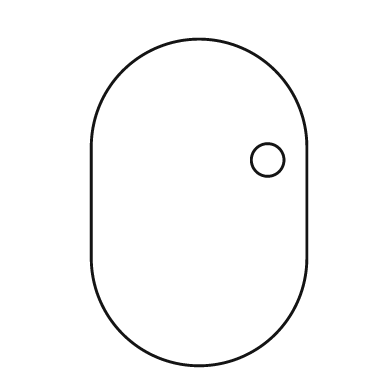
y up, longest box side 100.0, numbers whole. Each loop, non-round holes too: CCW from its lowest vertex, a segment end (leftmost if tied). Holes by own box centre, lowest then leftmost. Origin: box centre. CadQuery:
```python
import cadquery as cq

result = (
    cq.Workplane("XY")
    .moveTo(-33.0, -17.0)
    .threePointArc((0.0, -50.0), (33.0, -17.0))
    .lineTo(33.0, 17.0)
    .threePointArc((0.0, 50.0), (-33.0, 17.0))
    .close()
    .moveTo(21.0, 13.0)
    .circle(5.0)
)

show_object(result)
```